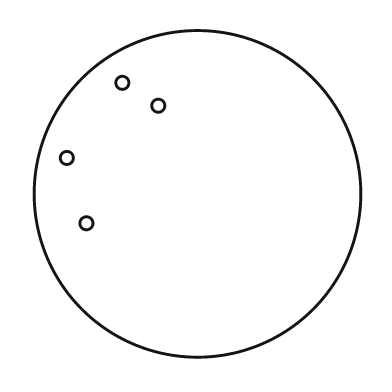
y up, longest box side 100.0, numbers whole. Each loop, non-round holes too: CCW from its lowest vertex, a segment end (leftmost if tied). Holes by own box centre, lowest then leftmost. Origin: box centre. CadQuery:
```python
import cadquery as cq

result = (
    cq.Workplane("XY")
    .moveTo(0.0, 0.0)
    .circle(50.0)
    .moveTo(-34.0, -9.0)
    .circle(2.0)
    .moveTo(-40.0, 11.0)
    .circle(2.0)
    .moveTo(-12.0, 27.0)
    .circle(2.0)
    .moveTo(-23.0, 34.0)
    .circle(2.0)
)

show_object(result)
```